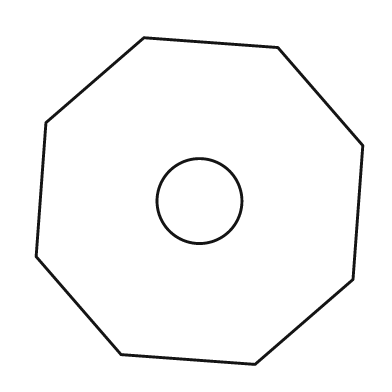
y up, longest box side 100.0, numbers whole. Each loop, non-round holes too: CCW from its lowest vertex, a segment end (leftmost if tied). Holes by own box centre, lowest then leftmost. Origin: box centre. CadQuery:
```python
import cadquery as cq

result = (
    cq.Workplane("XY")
    .moveTo(17.0, -50.0)
    .lineTo(47.0, -24.0)
    .lineTo(50.0, 17.0)
    .lineTo(24.0, 47.0)
    .lineTo(-17.0, 50.0)
    .lineTo(-47.0, 24.0)
    .lineTo(-50.0, -17.0)
    .lineTo(-24.0, -47.0)
    .close()
    .moveTo(0.0, 0.0)
    .circle(13.0)
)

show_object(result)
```